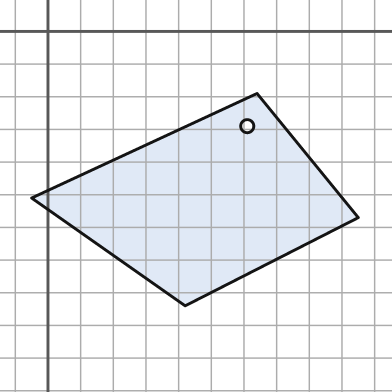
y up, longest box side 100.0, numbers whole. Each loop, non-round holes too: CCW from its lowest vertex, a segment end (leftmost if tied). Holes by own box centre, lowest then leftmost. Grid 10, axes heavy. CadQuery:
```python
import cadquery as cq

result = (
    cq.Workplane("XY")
    .moveTo(42.0, -84.0)
    .lineTo(95.0, -57.0)
    .lineTo(64.0, -19.0)
    .lineTo(-5.0, -51.0)
    .close()
    .moveTo(61.0, -29.0)
    .circle(2.0)
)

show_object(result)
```